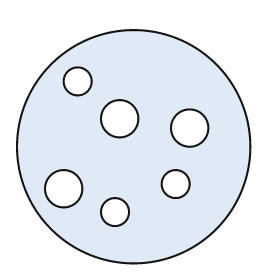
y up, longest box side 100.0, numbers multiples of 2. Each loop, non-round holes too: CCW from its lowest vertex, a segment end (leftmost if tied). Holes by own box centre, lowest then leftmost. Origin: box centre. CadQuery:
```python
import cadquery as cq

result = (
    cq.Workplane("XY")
    .moveTo(0.0, 0.0)
    .circle(50.0)
    .moveTo(-8.0, -28.0)
    .circle(6.0)
    .moveTo(-30.0, -18.0)
    .circle(8.0)
    .moveTo(18.0, -16.0)
    .circle(6.0)
    .moveTo(24.0, 8.0)
    .circle(8.0)
    .moveTo(-6.0, 12.0)
    .circle(8.0)
    .moveTo(-24.0, 28.0)
    .circle(6.0)
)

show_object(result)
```